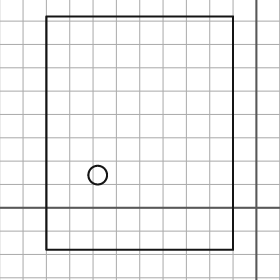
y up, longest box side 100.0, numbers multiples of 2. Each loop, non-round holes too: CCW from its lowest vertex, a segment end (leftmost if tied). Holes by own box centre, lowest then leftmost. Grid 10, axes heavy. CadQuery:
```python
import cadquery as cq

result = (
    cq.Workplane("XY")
    .moveTo(-90.0, -18.0)
    .lineTo(-10.0, -18.0)
    .lineTo(-10.0, 82.0)
    .lineTo(-90.0, 82.0)
    .close()
    .moveTo(-68.0, 14.0)
    .circle(4.0)
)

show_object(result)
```